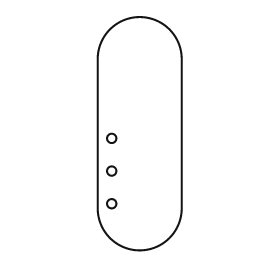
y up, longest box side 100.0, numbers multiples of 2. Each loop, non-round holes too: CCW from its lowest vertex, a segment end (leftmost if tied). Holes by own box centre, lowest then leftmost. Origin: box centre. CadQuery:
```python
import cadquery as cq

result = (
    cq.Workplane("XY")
    .moveTo(-18.0, -32.0)
    .threePointArc((0.0, -50.0), (18.0, -32.0))
    .lineTo(18.0, 32.0)
    .threePointArc((0.0, 50.0), (-18.0, 32.0))
    .close()
    .moveTo(-12.0, -30.0)
    .circle(2.0)
    .moveTo(-12.0, -16.0)
    .circle(2.0)
    .moveTo(-12.0, -2.0)
    .circle(2.0)
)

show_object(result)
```